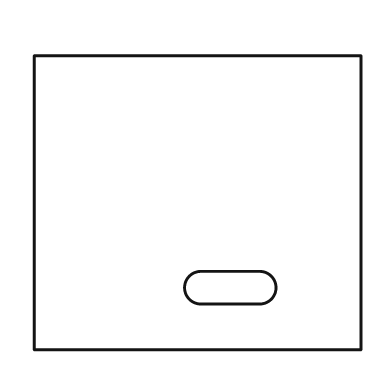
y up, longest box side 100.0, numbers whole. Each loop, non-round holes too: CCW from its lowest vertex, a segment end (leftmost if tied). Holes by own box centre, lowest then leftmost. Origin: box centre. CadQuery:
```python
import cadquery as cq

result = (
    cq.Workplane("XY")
    .moveTo(-50.0, -45.0)
    .lineTo(50.0, -45.0)
    .lineTo(50.0, 45.0)
    .lineTo(-50.0, 45.0)
    .close()
    .moveTo(1.0, -31.0)
    .lineTo(19.0, -31.0)
    .threePointArc((24.0, -26.0), (19.0, -21.0))
    .lineTo(1.0, -21.0)
    .threePointArc((-4.0, -26.0), (1.0, -31.0))
    .close()
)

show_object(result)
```